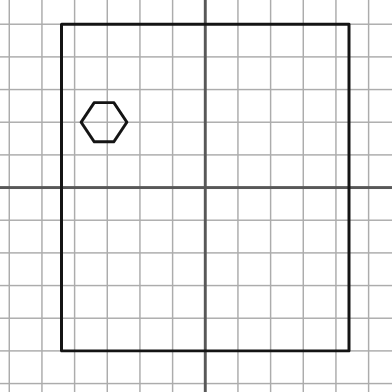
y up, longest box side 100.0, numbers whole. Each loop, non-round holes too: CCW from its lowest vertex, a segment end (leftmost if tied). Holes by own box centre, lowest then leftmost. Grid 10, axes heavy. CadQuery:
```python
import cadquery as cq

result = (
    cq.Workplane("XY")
    .moveTo(-44.0, -50.0)
    .lineTo(44.0, -50.0)
    .lineTo(44.0, 50.0)
    .lineTo(-44.0, 50.0)
    .close()
    .moveTo(-34.0, 14.0)
    .lineTo(-28.0, 14.0)
    .lineTo(-24.0, 20.0)
    .lineTo(-28.0, 26.0)
    .lineTo(-34.0, 26.0)
    .lineTo(-38.0, 20.0)
    .close()
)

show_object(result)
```